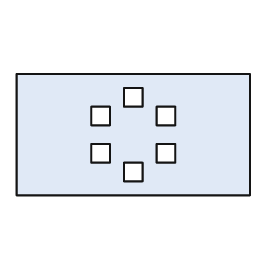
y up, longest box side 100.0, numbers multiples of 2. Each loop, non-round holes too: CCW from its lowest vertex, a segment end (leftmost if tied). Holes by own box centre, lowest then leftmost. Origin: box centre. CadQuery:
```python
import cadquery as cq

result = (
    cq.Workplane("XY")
    .moveTo(-50.0, -26.0)
    .lineTo(50.0, -26.0)
    .lineTo(50.0, 26.0)
    .lineTo(-50.0, 26.0)
    .close()
    .moveTo(-4.0, -20.0)
    .lineTo(4.0, -20.0)
    .lineTo(4.0, -12.0)
    .lineTo(-4.0, -12.0)
    .close()
    .moveTo(-18.0, -12.0)
    .lineTo(-10.0, -12.0)
    .lineTo(-10.0, -4.0)
    .lineTo(-18.0, -4.0)
    .close()
    .moveTo(10.0, -12.0)
    .lineTo(18.0, -12.0)
    .lineTo(18.0, -4.0)
    .lineTo(10.0, -4.0)
    .close()
    .moveTo(-18.0, 4.0)
    .lineTo(-10.0, 4.0)
    .lineTo(-10.0, 12.0)
    .lineTo(-18.0, 12.0)
    .close()
    .moveTo(10.0, 4.0)
    .lineTo(18.0, 4.0)
    .lineTo(18.0, 12.0)
    .lineTo(10.0, 12.0)
    .close()
    .moveTo(-4.0, 12.0)
    .lineTo(4.0, 12.0)
    .lineTo(4.0, 20.0)
    .lineTo(-4.0, 20.0)
    .close()
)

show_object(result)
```